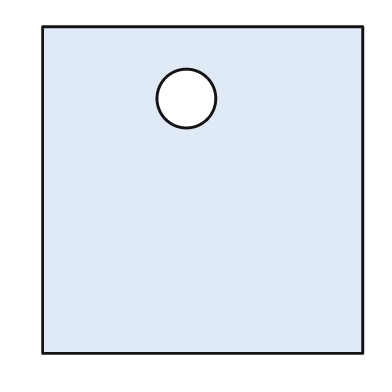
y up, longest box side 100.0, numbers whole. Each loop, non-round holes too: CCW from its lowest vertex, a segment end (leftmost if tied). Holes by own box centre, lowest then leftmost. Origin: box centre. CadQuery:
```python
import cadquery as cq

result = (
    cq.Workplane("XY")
    .moveTo(-49.0, -50.0)
    .lineTo(49.0, -50.0)
    .lineTo(49.0, 50.0)
    .lineTo(-49.0, 50.0)
    .close()
    .moveTo(-5.0, 28.0)
    .circle(9.0)
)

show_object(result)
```